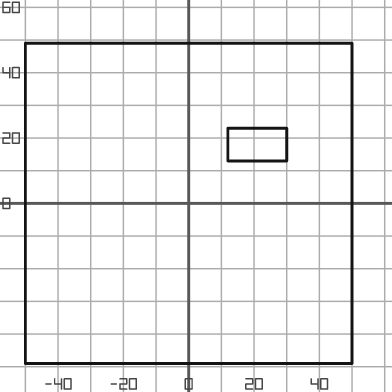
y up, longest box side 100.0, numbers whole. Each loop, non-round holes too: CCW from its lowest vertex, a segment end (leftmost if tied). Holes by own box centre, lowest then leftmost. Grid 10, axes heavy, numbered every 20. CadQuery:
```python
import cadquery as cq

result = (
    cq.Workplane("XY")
    .moveTo(-50.0, -49.0)
    .lineTo(50.0, -49.0)
    .lineTo(50.0, 49.0)
    .lineTo(-50.0, 49.0)
    .close()
    .moveTo(12.0, 13.0)
    .lineTo(30.0, 13.0)
    .lineTo(30.0, 23.0)
    .lineTo(12.0, 23.0)
    .close()
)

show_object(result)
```